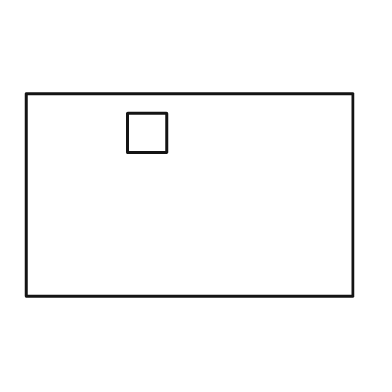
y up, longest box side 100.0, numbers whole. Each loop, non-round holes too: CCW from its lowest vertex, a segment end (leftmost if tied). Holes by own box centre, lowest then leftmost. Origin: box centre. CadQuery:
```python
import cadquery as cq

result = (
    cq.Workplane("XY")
    .moveTo(-50.0, -31.0)
    .lineTo(50.0, -31.0)
    .lineTo(50.0, 31.0)
    .lineTo(-50.0, 31.0)
    .close()
    .moveTo(-19.0, 13.0)
    .lineTo(-7.0, 13.0)
    .lineTo(-7.0, 25.0)
    .lineTo(-19.0, 25.0)
    .close()
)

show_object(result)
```